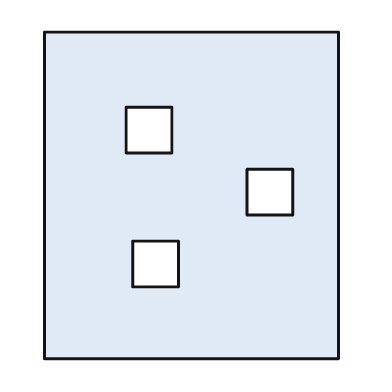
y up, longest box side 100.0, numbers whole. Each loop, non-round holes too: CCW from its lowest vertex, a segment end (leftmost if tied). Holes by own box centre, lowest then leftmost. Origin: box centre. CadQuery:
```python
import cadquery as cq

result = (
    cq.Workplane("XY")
    .moveTo(-45.0, -50.0)
    .lineTo(45.0, -50.0)
    .lineTo(45.0, 50.0)
    .lineTo(-45.0, 50.0)
    .close()
    .moveTo(-18.0, -28.0)
    .lineTo(-4.0, -28.0)
    .lineTo(-4.0, -14.0)
    .lineTo(-18.0, -14.0)
    .close()
    .moveTo(17.0, -6.0)
    .lineTo(31.0, -6.0)
    .lineTo(31.0, 8.0)
    .lineTo(17.0, 8.0)
    .close()
    .moveTo(-20.0, 13.0)
    .lineTo(-6.0, 13.0)
    .lineTo(-6.0, 27.0)
    .lineTo(-20.0, 27.0)
    .close()
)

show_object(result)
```